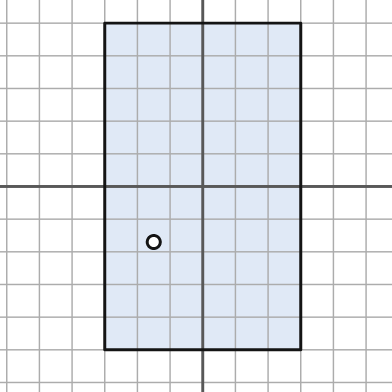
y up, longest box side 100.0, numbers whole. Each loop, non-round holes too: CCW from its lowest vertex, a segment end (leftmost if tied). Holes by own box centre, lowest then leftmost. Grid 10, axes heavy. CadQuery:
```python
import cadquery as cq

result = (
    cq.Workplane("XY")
    .moveTo(-30.0, -50.0)
    .lineTo(30.0, -50.0)
    .lineTo(30.0, 50.0)
    .lineTo(-30.0, 50.0)
    .close()
    .moveTo(-15.0, -17.0)
    .circle(2.0)
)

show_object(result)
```